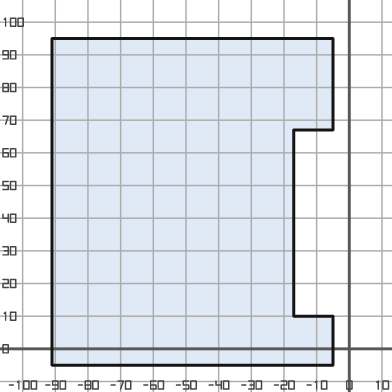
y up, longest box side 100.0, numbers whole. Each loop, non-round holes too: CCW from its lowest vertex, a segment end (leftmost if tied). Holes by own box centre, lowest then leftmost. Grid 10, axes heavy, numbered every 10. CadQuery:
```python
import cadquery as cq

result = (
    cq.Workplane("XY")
    .moveTo(-91.0, -5.0)
    .lineTo(-5.0, -5.0)
    .lineTo(-5.0, 10.0)
    .lineTo(-17.0, 10.0)
    .lineTo(-17.0, 67.0)
    .lineTo(-5.0, 67.0)
    .lineTo(-5.0, 95.0)
    .lineTo(-91.0, 95.0)
    .close()
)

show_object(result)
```